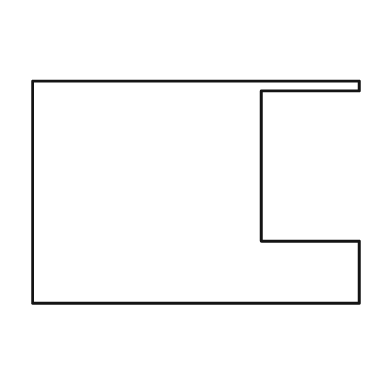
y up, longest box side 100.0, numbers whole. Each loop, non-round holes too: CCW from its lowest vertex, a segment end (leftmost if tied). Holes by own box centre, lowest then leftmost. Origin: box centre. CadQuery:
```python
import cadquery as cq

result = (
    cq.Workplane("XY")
    .moveTo(-50.0, -34.0)
    .lineTo(50.0, -34.0)
    .lineTo(50.0, -15.0)
    .lineTo(20.0, -15.0)
    .lineTo(20.0, 31.0)
    .lineTo(50.0, 31.0)
    .lineTo(50.0, 34.0)
    .lineTo(-50.0, 34.0)
    .close()
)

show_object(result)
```